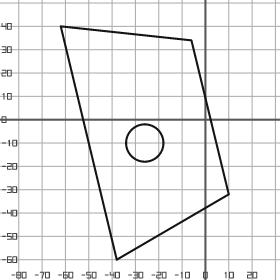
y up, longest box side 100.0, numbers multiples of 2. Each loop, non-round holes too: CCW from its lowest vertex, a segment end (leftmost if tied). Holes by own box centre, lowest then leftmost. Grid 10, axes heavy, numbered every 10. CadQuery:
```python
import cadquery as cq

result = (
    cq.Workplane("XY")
    .moveTo(-38.0, -60.0)
    .lineTo(10.0, -32.0)
    .lineTo(-6.0, 34.0)
    .lineTo(-62.0, 40.0)
    .close()
    .moveTo(-26.0, -10.0)
    .circle(8.0)
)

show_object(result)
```